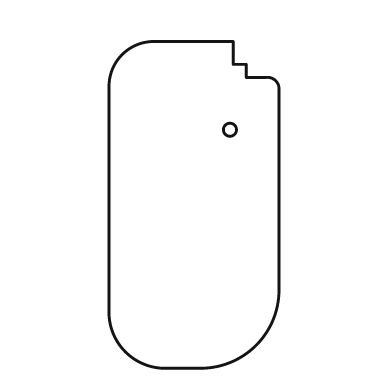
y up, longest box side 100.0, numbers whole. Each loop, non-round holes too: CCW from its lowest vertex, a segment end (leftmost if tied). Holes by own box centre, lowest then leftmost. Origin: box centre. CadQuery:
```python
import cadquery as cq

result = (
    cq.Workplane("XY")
    .moveTo(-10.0, -50.0)
    .lineTo(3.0, -50.0)
    .threePointArc((19.0, -43.0), (26.0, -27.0))
    .lineTo(26.0, 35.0)
    .threePointArc((25.0, 38.0), (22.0, 39.0))
    .lineTo(16.0, 39.0)
    .lineTo(16.0, 43.0)
    .lineTo(12.0, 43.0)
    .lineTo(12.0, 50.0)
    .lineTo(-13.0, 50.0)
    .threePointArc((-22.0, 46.0), (-26.0, 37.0))
    .lineTo(-26.0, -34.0)
    .threePointArc((-21.0, -45.0), (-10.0, -50.0))
    .close()
    .moveTo(11.0, 23.0)
    .circle(2.0)
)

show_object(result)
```